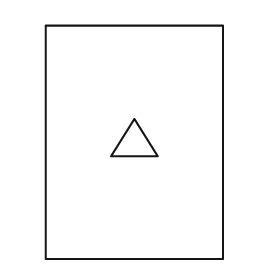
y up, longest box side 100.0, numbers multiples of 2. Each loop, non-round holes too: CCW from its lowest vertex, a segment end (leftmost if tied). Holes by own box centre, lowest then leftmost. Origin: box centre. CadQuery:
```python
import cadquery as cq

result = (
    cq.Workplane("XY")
    .moveTo(-38.0, -50.0)
    .lineTo(38.0, -50.0)
    .lineTo(38.0, 50.0)
    .lineTo(-38.0, 50.0)
    .close()
    .moveTo(-10.0, -6.0)
    .lineTo(10.0, -6.0)
    .lineTo(0.0, 10.0)
    .close()
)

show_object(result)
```